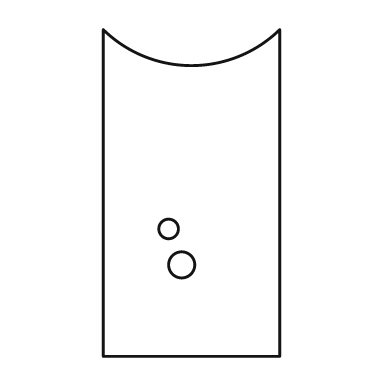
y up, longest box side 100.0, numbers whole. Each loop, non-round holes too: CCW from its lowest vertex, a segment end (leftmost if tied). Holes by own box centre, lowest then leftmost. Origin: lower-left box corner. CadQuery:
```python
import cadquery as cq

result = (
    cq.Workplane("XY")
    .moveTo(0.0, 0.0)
    .lineTo(54.0, 0.0)
    .lineTo(54.0, 100.0)
    .threePointArc((27.0, 89.0), (0.0, 100.0))
    .close()
    .moveTo(24.0, 28.0)
    .circle(4.0)
    .moveTo(20.0, 39.0)
    .circle(3.0)
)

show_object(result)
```